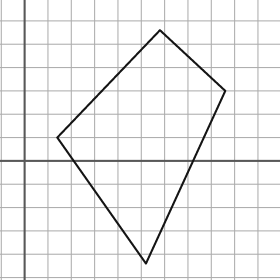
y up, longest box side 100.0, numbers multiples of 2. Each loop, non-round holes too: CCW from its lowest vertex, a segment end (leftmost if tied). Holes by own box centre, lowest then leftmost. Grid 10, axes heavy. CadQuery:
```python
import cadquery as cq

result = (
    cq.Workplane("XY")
    .moveTo(52.0, -44.0)
    .lineTo(86.0, 30.0)
    .lineTo(58.0, 56.0)
    .lineTo(14.0, 10.0)
    .close()
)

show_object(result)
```